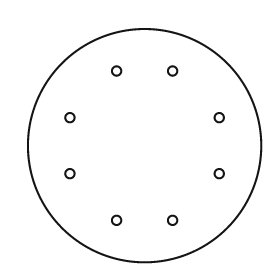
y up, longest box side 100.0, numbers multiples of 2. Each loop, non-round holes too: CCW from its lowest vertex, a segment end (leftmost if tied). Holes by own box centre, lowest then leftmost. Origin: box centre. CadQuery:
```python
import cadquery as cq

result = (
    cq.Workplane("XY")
    .moveTo(0.0, 0.0)
    .circle(50.0)
    .moveTo(-12.0, -32.0)
    .circle(2.0)
    .moveTo(12.0, -32.0)
    .circle(2.0)
    .moveTo(-32.0, -12.0)
    .circle(2.0)
    .moveTo(32.0, -12.0)
    .circle(2.0)
    .moveTo(-32.0, 12.0)
    .circle(2.0)
    .moveTo(32.0, 12.0)
    .circle(2.0)
    .moveTo(-12.0, 32.0)
    .circle(2.0)
    .moveTo(12.0, 32.0)
    .circle(2.0)
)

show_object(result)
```